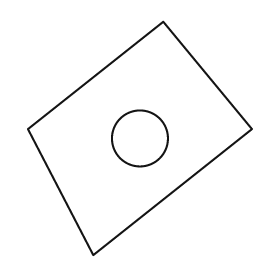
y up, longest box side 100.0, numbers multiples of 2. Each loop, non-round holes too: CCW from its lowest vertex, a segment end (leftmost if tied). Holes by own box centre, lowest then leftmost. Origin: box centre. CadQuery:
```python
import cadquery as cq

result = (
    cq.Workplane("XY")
    .moveTo(-20.0, -50.0)
    .lineTo(48.0, 4.0)
    .lineTo(10.0, 50.0)
    .lineTo(-48.0, 4.0)
    .close()
    .moveTo(0.0, 0.0)
    .circle(12.0)
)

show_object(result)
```